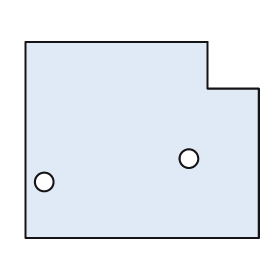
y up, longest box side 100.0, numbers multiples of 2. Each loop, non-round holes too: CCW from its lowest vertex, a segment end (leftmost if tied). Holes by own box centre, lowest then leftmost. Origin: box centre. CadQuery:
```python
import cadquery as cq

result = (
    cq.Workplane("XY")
    .moveTo(-50.0, -42.0)
    .lineTo(50.0, -42.0)
    .lineTo(50.0, 22.0)
    .lineTo(28.0, 22.0)
    .lineTo(28.0, 42.0)
    .lineTo(-50.0, 42.0)
    .close()
    .moveTo(-42.0, -18.0)
    .circle(4.0)
    .moveTo(20.0, -8.0)
    .circle(4.0)
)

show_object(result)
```